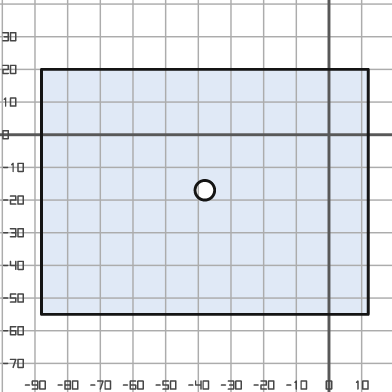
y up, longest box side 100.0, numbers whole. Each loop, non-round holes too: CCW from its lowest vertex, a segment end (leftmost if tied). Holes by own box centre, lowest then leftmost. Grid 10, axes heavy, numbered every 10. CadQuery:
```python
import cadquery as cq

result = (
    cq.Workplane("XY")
    .moveTo(-88.0, -55.0)
    .lineTo(12.0, -55.0)
    .lineTo(12.0, 20.0)
    .lineTo(-88.0, 20.0)
    .close()
    .moveTo(-38.0, -17.0)
    .circle(3.0)
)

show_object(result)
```